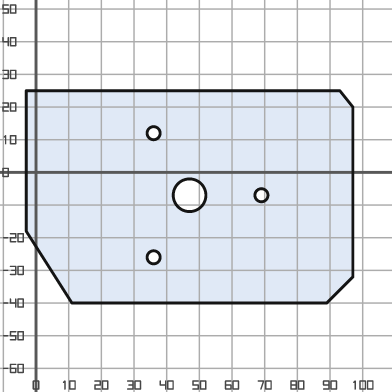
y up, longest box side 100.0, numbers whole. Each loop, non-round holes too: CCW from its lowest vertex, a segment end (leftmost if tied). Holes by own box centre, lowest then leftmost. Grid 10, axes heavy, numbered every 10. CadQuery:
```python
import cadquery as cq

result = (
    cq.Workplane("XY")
    .moveTo(11.0, -40.0)
    .lineTo(89.0, -40.0)
    .lineTo(97.0, -32.0)
    .lineTo(97.0, 20.0)
    .lineTo(93.0, 25.0)
    .lineTo(-3.0, 25.0)
    .lineTo(-3.0, -18.0)
    .close()
    .moveTo(36.0, -26.0)
    .circle(2.0)
    .moveTo(47.0, -7.0)
    .circle(5.0)
    .moveTo(69.0, -7.0)
    .circle(2.0)
    .moveTo(36.0, 12.0)
    .circle(2.0)
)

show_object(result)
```